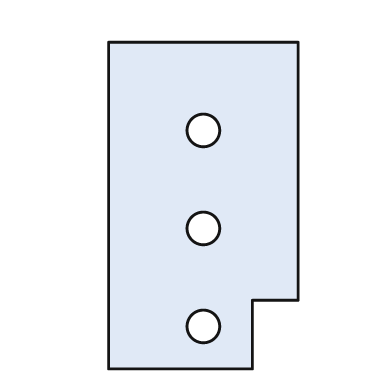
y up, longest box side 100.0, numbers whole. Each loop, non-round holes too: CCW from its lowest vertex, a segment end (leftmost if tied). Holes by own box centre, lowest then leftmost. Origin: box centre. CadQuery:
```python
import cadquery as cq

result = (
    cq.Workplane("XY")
    .moveTo(-29.0, -50.0)
    .lineTo(15.0, -50.0)
    .lineTo(15.0, -29.0)
    .lineTo(29.0, -29.0)
    .lineTo(29.0, 50.0)
    .lineTo(-29.0, 50.0)
    .close()
    .moveTo(0.0, -37.0)
    .circle(5.0)
    .moveTo(0.0, -7.0)
    .circle(5.0)
    .moveTo(0.0, 23.0)
    .circle(5.0)
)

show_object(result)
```